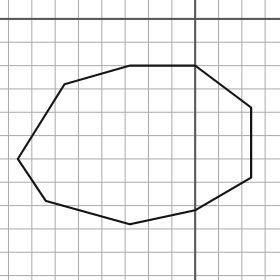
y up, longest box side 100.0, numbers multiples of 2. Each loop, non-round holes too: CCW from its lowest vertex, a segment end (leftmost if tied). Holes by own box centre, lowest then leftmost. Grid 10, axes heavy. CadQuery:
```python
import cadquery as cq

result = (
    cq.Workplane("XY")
    .moveTo(-28.0, -88.0)
    .lineTo(0.0, -82.0)
    .lineTo(24.0, -68.0)
    .lineTo(24.0, -38.0)
    .lineTo(0.0, -20.0)
    .lineTo(-28.0, -20.0)
    .lineTo(-56.0, -28.0)
    .lineTo(-76.0, -60.0)
    .lineTo(-64.0, -78.0)
    .close()
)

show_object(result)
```